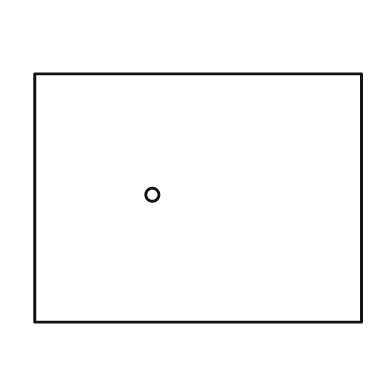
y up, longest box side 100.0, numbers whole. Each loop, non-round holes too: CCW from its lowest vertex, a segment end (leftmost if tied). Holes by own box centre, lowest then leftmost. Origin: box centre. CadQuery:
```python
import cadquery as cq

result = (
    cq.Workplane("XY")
    .moveTo(-50.0, -38.0)
    .lineTo(50.0, -38.0)
    .lineTo(50.0, 38.0)
    .lineTo(-50.0, 38.0)
    .close()
    .moveTo(-14.0, 1.0)
    .circle(2.0)
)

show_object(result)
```